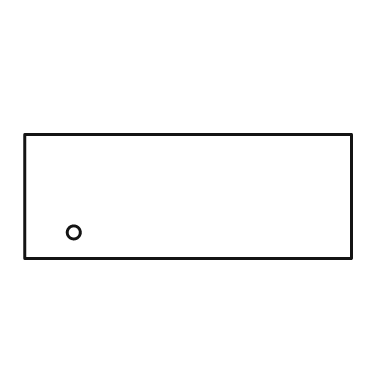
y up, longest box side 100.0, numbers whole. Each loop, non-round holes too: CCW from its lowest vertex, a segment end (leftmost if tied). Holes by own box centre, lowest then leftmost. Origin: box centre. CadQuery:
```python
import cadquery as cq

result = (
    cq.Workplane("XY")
    .moveTo(-50.0, -19.0)
    .lineTo(50.0, -19.0)
    .lineTo(50.0, 19.0)
    .lineTo(-50.0, 19.0)
    .close()
    .moveTo(-35.0, -11.0)
    .circle(2.0)
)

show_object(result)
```